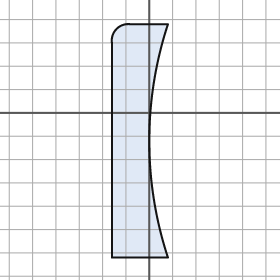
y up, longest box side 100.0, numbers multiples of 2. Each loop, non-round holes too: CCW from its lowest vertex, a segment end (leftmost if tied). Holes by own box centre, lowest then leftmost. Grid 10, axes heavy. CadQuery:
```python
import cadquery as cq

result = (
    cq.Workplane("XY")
    .moveTo(-16.0, -62.0)
    .lineTo(8.0, -62.0)
    .threePointArc((0.0, -12.0), (8.0, 38.0))
    .lineTo(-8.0, 38.0)
    .threePointArc((-14.0, 36.0), (-16.0, 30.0))
    .close()
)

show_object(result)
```